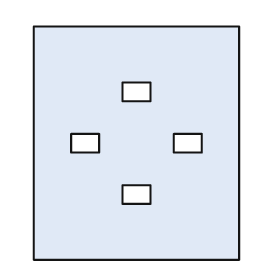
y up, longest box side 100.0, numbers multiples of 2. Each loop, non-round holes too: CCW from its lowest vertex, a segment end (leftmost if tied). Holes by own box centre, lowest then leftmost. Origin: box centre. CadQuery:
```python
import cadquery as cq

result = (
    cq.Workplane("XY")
    .moveTo(-44.0, -50.0)
    .lineTo(44.0, -50.0)
    .lineTo(44.0, 50.0)
    .lineTo(-44.0, 50.0)
    .close()
    .moveTo(-6.0, -26.0)
    .lineTo(6.0, -26.0)
    .lineTo(6.0, -18.0)
    .lineTo(-6.0, -18.0)
    .close()
    .moveTo(-28.0, -4.0)
    .lineTo(-16.0, -4.0)
    .lineTo(-16.0, 4.0)
    .lineTo(-28.0, 4.0)
    .close()
    .moveTo(16.0, -4.0)
    .lineTo(28.0, -4.0)
    .lineTo(28.0, 4.0)
    .lineTo(16.0, 4.0)
    .close()
    .moveTo(-6.0, 18.0)
    .lineTo(6.0, 18.0)
    .lineTo(6.0, 26.0)
    .lineTo(-6.0, 26.0)
    .close()
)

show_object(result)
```